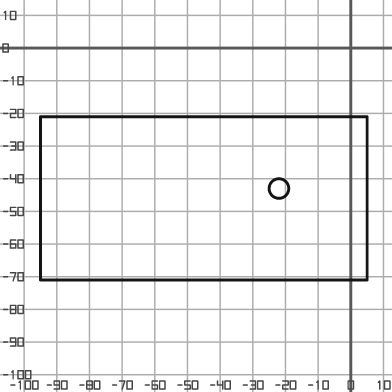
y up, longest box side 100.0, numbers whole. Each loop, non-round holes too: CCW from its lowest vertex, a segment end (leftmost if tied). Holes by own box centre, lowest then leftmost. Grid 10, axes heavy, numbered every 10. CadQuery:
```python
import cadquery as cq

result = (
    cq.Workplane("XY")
    .moveTo(-95.0, -71.0)
    .lineTo(5.0, -71.0)
    .lineTo(5.0, -21.0)
    .lineTo(-95.0, -21.0)
    .close()
    .moveTo(-22.0, -43.0)
    .circle(3.0)
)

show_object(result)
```